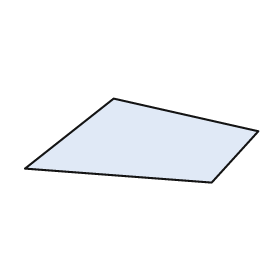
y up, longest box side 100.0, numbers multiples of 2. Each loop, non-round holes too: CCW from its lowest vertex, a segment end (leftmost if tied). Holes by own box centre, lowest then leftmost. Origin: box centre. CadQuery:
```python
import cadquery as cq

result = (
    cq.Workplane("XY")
    .moveTo(30.0, -18.0)
    .lineTo(50.0, 4.0)
    .lineTo(-12.0, 18.0)
    .lineTo(-50.0, -12.0)
    .close()
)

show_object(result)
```